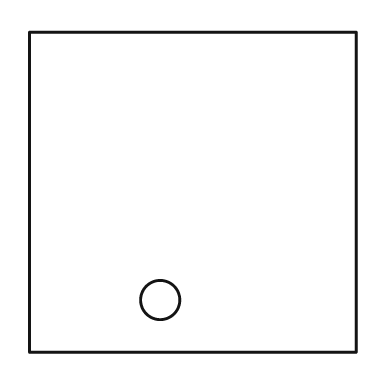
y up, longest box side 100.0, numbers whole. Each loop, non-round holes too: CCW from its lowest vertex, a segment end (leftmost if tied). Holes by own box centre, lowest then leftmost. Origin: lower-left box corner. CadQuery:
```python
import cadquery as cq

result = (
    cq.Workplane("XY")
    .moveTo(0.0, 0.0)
    .lineTo(100.0, 0.0)
    .lineTo(100.0, 98.0)
    .lineTo(0.0, 98.0)
    .close()
    .moveTo(40.0, 16.0)
    .circle(6.0)
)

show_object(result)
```